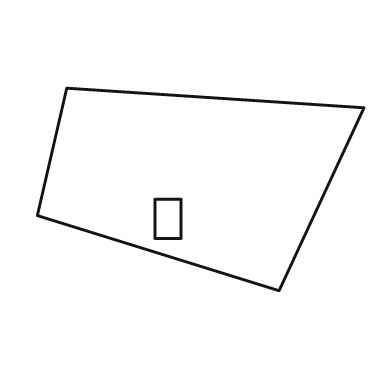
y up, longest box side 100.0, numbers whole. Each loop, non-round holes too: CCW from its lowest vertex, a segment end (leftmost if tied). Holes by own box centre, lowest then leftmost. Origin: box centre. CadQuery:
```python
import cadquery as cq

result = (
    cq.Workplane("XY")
    .moveTo(24.0, -31.0)
    .lineTo(50.0, 25.0)
    .lineTo(-41.0, 31.0)
    .lineTo(-50.0, -8.0)
    .close()
    .moveTo(-14.0, -15.0)
    .lineTo(-6.0, -15.0)
    .lineTo(-6.0, -3.0)
    .lineTo(-14.0, -3.0)
    .close()
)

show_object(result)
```